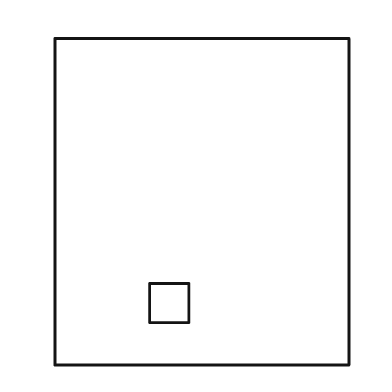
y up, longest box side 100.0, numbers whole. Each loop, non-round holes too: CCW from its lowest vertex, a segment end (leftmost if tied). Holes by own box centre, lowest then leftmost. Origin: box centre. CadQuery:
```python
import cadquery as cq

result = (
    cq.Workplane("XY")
    .moveTo(-45.0, -50.0)
    .lineTo(45.0, -50.0)
    .lineTo(45.0, 50.0)
    .lineTo(-45.0, 50.0)
    .close()
    .moveTo(-16.0, -37.0)
    .lineTo(-4.0, -37.0)
    .lineTo(-4.0, -25.0)
    .lineTo(-16.0, -25.0)
    .close()
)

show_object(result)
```